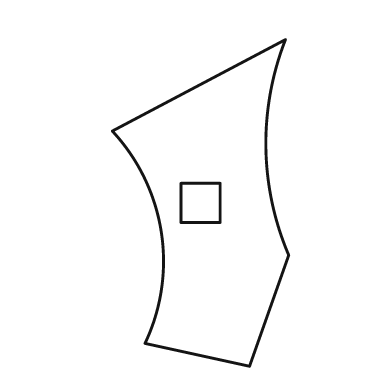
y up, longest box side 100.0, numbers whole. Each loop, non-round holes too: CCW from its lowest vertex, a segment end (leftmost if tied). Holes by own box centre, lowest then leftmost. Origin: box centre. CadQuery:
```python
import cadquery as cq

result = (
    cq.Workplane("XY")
    .moveTo(15.0, -50.0)
    .lineTo(27.0, -16.0)
    .threePointArc((20.0, 17.0), (26.0, 50.0))
    .lineTo(-27.0, 22.0)
    .threePointArc((-12.0, -9.0), (-17.0, -43.0))
    .close()
    .moveTo(-6.0, -6.0)
    .lineTo(6.0, -6.0)
    .lineTo(6.0, 6.0)
    .lineTo(-6.0, 6.0)
    .close()
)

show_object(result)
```